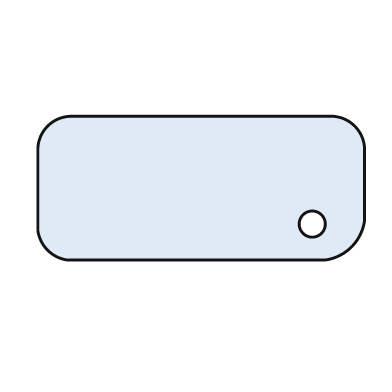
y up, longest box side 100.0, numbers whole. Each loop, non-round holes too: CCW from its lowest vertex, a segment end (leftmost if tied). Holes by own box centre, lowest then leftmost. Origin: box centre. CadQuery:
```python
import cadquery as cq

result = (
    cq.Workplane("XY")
    .moveTo(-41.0, -22.0)
    .lineTo(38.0, -22.0)
    .threePointArc((46.0, -18.0), (50.0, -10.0))
    .lineTo(50.0, 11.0)
    .threePointArc((47.0, 19.0), (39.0, 22.0))
    .lineTo(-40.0, 22.0)
    .threePointArc((-47.0, 19.0), (-50.0, 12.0))
    .lineTo(-50.0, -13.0)
    .threePointArc((-47.0, -19.0), (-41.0, -22.0))
    .close()
    .moveTo(34.0, -11.0)
    .circle(4.0)
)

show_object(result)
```